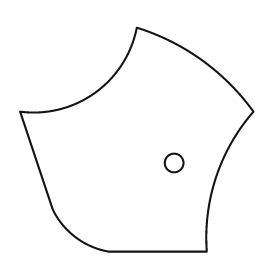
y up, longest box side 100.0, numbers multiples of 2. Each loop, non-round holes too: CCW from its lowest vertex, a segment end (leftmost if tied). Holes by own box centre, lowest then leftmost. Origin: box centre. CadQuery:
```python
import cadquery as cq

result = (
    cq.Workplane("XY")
    .moveTo(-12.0, -48.0)
    .lineTo(30.0, -48.0)
    .threePointArc((34.0, -16.0), (50.0, 12.0))
    .threePointArc((28.0, 34.0), (0.0, 48.0))
    .threePointArc((-18.0, 20.0), (-50.0, 12.0))
    .lineTo(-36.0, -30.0)
    .threePointArc((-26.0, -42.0), (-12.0, -48.0))
    .close()
    .moveTo(16.0, -10.0)
    .circle(4.0)
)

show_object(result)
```